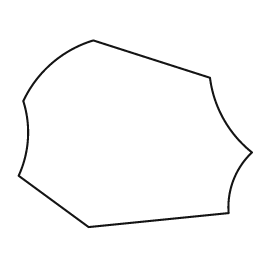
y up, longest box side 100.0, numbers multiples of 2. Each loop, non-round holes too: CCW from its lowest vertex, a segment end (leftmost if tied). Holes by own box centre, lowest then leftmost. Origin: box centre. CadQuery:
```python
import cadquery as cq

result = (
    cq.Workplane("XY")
    .moveTo(-20.0, -40.0)
    .lineTo(40.0, -34.0)
    .threePointArc((42.0, -20.0), (50.0, -8.0))
    .threePointArc((38.0, 6.0), (32.0, 24.0))
    .lineTo(-18.0, 40.0)
    .threePointArc((-36.0, 30.0), (-48.0, 14.0))
    .threePointArc((-46.0, -2.0), (-50.0, -18.0))
    .close()
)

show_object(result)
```